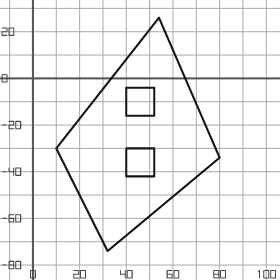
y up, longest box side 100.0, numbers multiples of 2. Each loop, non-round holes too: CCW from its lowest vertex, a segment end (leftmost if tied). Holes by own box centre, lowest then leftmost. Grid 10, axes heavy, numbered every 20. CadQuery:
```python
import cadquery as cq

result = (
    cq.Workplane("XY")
    .moveTo(32.0, -74.0)
    .lineTo(80.0, -34.0)
    .lineTo(54.0, 26.0)
    .lineTo(10.0, -30.0)
    .close()
    .moveTo(40.0, -42.0)
    .lineTo(52.0, -42.0)
    .lineTo(52.0, -30.0)
    .lineTo(40.0, -30.0)
    .close()
    .moveTo(40.0, -16.0)
    .lineTo(52.0, -16.0)
    .lineTo(52.0, -4.0)
    .lineTo(40.0, -4.0)
    .close()
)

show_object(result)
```